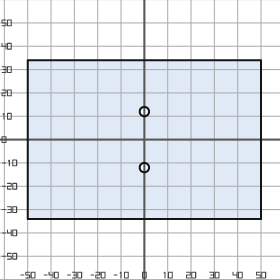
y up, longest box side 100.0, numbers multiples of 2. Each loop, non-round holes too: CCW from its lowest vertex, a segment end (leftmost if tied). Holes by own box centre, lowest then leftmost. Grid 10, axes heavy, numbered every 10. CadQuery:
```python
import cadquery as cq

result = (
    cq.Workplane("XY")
    .moveTo(-50.0, -34.0)
    .lineTo(50.0, -34.0)
    .lineTo(50.0, 34.0)
    .lineTo(-50.0, 34.0)
    .close()
    .moveTo(0.0, -12.0)
    .circle(2.0)
    .moveTo(0.0, 12.0)
    .circle(2.0)
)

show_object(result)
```